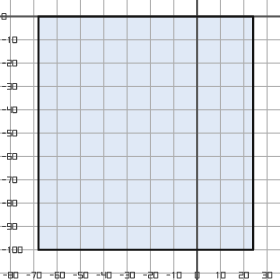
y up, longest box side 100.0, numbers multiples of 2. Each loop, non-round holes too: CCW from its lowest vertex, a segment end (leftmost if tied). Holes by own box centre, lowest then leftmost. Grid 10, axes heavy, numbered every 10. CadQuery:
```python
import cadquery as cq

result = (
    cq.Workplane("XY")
    .moveTo(-68.0, -100.0)
    .lineTo(24.0, -100.0)
    .lineTo(24.0, 0.0)
    .lineTo(-68.0, 0.0)
    .close()
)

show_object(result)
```